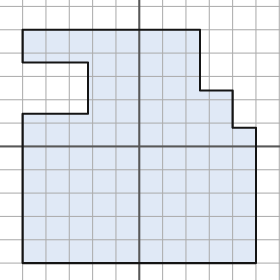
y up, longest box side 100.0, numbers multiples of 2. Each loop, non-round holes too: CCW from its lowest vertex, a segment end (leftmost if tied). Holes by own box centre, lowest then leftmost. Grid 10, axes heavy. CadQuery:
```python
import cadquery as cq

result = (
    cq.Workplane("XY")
    .moveTo(-50.0, -50.0)
    .lineTo(50.0, -50.0)
    .lineTo(50.0, 8.0)
    .lineTo(40.0, 8.0)
    .lineTo(40.0, 24.0)
    .lineTo(26.0, 24.0)
    .lineTo(26.0, 50.0)
    .lineTo(-50.0, 50.0)
    .lineTo(-50.0, 36.0)
    .lineTo(-22.0, 36.0)
    .lineTo(-22.0, 14.0)
    .lineTo(-50.0, 14.0)
    .close()
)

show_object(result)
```